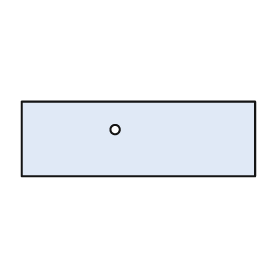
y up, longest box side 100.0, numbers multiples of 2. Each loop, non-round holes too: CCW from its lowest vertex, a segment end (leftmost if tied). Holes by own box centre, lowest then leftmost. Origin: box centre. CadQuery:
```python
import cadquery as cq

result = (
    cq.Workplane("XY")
    .moveTo(-50.0, -16.0)
    .lineTo(50.0, -16.0)
    .lineTo(50.0, 16.0)
    .lineTo(-50.0, 16.0)
    .close()
    .moveTo(-10.0, 4.0)
    .circle(2.0)
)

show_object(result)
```